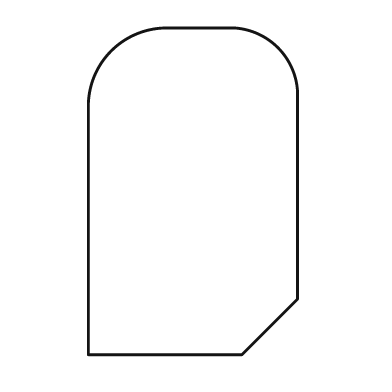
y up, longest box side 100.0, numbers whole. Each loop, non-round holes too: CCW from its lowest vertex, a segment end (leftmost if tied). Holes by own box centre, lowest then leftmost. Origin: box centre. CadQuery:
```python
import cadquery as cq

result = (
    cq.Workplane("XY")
    .moveTo(-32.0, -50.0)
    .lineTo(15.0, -50.0)
    .lineTo(32.0, -33.0)
    .lineTo(32.0, 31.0)
    .threePointArc((26.0, 44.0), (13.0, 50.0))
    .lineTo(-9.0, 50.0)
    .threePointArc((-25.0, 43.0), (-32.0, 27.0))
    .close()
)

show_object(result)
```